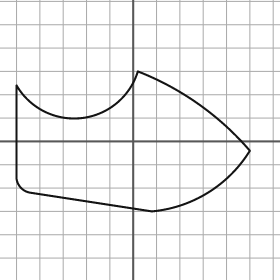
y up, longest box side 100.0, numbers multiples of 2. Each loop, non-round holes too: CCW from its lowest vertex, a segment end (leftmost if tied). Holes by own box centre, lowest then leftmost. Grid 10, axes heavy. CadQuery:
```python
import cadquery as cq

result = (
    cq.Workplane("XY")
    .moveTo(8.0, -30.0)
    .threePointArc((32.0, -22.0), (50.0, -4.0))
    .threePointArc((28.0, 16.0), (2.0, 30.0))
    .threePointArc((-22.0, 10.0), (-50.0, 24.0))
    .lineTo(-50.0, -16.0)
    .threePointArc((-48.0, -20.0), (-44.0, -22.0))
    .close()
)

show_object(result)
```